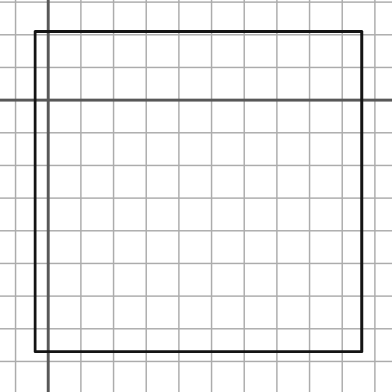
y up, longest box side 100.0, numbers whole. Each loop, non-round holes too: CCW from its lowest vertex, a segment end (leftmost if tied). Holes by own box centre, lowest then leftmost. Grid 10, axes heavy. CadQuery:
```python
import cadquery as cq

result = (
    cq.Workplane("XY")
    .moveTo(-4.0, -77.0)
    .lineTo(96.0, -77.0)
    .lineTo(96.0, 21.0)
    .lineTo(-4.0, 21.0)
    .close()
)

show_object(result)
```